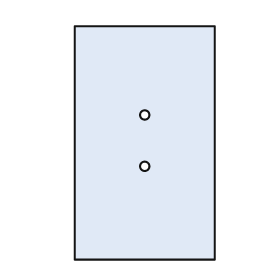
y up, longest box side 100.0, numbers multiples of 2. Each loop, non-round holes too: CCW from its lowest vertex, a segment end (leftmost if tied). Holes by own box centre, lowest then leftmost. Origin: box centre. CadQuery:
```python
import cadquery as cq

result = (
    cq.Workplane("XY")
    .moveTo(-30.0, -50.0)
    .lineTo(30.0, -50.0)
    .lineTo(30.0, 50.0)
    .lineTo(-30.0, 50.0)
    .close()
    .moveTo(0.0, -10.0)
    .circle(2.0)
    .moveTo(0.0, 12.0)
    .circle(2.0)
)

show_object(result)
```